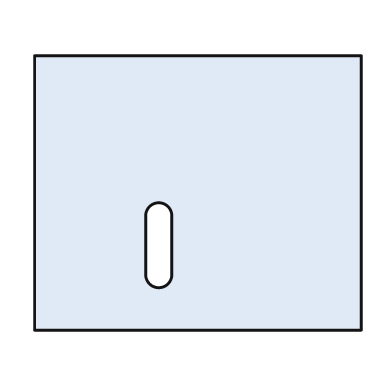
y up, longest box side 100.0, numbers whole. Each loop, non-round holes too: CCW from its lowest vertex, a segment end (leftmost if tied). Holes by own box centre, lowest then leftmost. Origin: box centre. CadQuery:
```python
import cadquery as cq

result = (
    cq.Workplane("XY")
    .moveTo(-50.0, -42.0)
    .lineTo(50.0, -42.0)
    .lineTo(50.0, 42.0)
    .lineTo(-50.0, 42.0)
    .close()
    .moveTo(-16.0, -25.0)
    .threePointArc((-12.0, -29.0), (-8.0, -25.0))
    .lineTo(-8.0, -7.0)
    .threePointArc((-12.0, -3.0), (-16.0, -7.0))
    .close()
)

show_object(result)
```